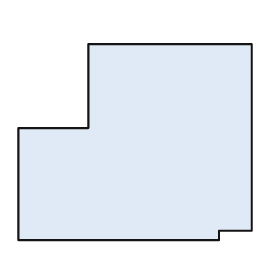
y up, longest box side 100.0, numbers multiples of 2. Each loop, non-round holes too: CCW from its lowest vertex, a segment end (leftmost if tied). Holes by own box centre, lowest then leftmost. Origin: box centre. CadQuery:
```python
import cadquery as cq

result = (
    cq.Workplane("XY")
    .moveTo(-50.0, -42.0)
    .lineTo(36.0, -42.0)
    .lineTo(36.0, -38.0)
    .lineTo(50.0, -38.0)
    .lineTo(50.0, 42.0)
    .lineTo(-20.0, 42.0)
    .lineTo(-20.0, 6.0)
    .lineTo(-50.0, 6.0)
    .close()
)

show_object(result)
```